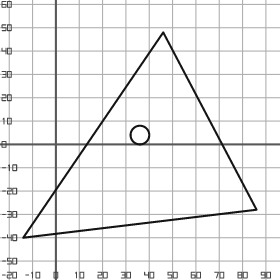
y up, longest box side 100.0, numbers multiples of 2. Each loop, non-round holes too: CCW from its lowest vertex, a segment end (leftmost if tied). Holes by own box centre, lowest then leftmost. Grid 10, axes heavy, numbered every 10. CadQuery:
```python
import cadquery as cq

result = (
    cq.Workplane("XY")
    .moveTo(-14.0, -40.0)
    .lineTo(86.0, -28.0)
    .lineTo(46.0, 48.0)
    .close()
    .moveTo(36.0, 4.0)
    .circle(4.0)
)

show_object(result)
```